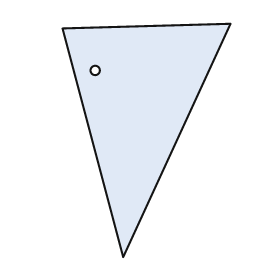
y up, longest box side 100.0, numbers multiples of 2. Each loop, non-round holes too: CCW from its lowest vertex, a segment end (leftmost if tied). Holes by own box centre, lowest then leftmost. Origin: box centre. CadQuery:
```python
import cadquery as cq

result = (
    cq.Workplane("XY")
    .moveTo(-10.0, -50.0)
    .lineTo(36.0, 50.0)
    .lineTo(-36.0, 48.0)
    .close()
    .moveTo(-22.0, 30.0)
    .circle(2.0)
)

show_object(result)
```